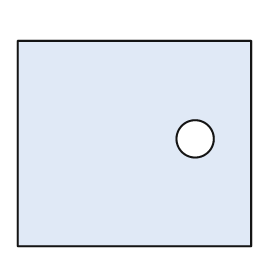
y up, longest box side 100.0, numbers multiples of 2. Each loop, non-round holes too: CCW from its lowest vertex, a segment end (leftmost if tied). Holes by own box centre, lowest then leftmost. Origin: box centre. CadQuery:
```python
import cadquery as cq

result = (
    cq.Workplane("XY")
    .moveTo(-50.0, -44.0)
    .lineTo(50.0, -44.0)
    .lineTo(50.0, 44.0)
    .lineTo(-50.0, 44.0)
    .close()
    .moveTo(26.0, 2.0)
    .circle(8.0)
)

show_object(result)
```